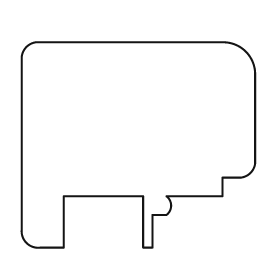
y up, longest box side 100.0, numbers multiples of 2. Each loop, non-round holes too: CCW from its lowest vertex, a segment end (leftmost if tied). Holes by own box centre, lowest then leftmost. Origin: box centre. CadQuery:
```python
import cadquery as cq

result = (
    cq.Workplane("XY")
    .moveTo(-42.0, -44.0)
    .lineTo(-32.0, -44.0)
    .lineTo(-32.0, -22.0)
    .lineTo(2.0, -22.0)
    .lineTo(2.0, -44.0)
    .lineTo(6.0, -44.0)
    .lineTo(6.0, -30.0)
    .lineTo(12.0, -30.0)
    .threePointArc((14.0, -26.0), (12.0, -22.0))
    .lineTo(36.0, -22.0)
    .lineTo(36.0, -14.0)
    .lineTo(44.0, -14.0)
    .threePointArc((48.0, -12.0), (50.0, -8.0))
    .lineTo(50.0, 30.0)
    .threePointArc((46.0, 40.0), (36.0, 44.0))
    .lineTo(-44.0, 44.0)
    .threePointArc((-48.0, 42.0), (-50.0, 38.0))
    .lineTo(-50.0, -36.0)
    .threePointArc((-48.0, -42.0), (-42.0, -44.0))
    .close()
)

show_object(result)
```